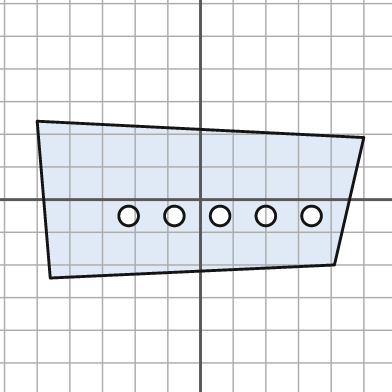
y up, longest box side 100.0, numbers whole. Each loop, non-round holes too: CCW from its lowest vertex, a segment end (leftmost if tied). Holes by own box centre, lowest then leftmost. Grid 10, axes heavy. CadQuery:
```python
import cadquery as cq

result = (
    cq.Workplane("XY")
    .moveTo(-46.0, -24.0)
    .lineTo(41.0, -20.0)
    .lineTo(50.0, 19.0)
    .lineTo(-50.0, 24.0)
    .close()
    .moveTo(-22.0, -5.0)
    .circle(3.0)
    .moveTo(-8.0, -5.0)
    .circle(3.0)
    .moveTo(6.0, -5.0)
    .circle(3.0)
    .moveTo(20.0, -5.0)
    .circle(3.0)
    .moveTo(34.0, -5.0)
    .circle(3.0)
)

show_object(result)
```